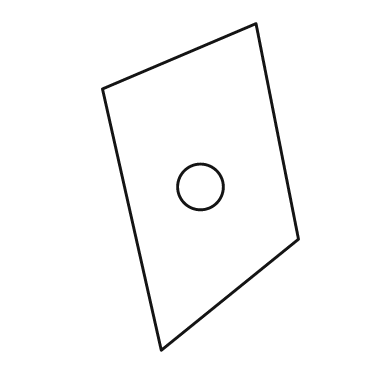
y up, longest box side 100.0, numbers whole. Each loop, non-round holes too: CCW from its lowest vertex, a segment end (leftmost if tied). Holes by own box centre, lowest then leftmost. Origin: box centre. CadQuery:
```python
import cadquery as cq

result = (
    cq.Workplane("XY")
    .moveTo(-12.0, -50.0)
    .lineTo(30.0, -16.0)
    .lineTo(17.0, 50.0)
    .lineTo(-30.0, 30.0)
    .close()
    .moveTo(0.0, 0.0)
    .circle(7.0)
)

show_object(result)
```